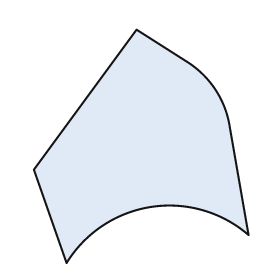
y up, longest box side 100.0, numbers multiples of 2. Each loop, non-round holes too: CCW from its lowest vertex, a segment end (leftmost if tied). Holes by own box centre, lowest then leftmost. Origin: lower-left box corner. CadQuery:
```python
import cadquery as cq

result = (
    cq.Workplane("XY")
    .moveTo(14.0, 0.0)
    .threePointArc((50.0, 24.0), (92.0, 12.0))
    .lineTo(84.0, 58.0)
    .threePointArc((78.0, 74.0), (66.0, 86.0))
    .lineTo(44.0, 100.0)
    .lineTo(0.0, 40.0)
    .close()
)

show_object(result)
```